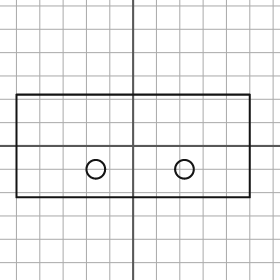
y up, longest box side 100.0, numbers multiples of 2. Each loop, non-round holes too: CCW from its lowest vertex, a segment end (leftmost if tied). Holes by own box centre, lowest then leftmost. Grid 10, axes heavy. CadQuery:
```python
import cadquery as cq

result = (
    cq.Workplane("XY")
    .moveTo(-50.0, -22.0)
    .lineTo(50.0, -22.0)
    .lineTo(50.0, 22.0)
    .lineTo(-50.0, 22.0)
    .close()
    .moveTo(-16.0, -10.0)
    .circle(4.0)
    .moveTo(22.0, -10.0)
    .circle(4.0)
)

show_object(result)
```